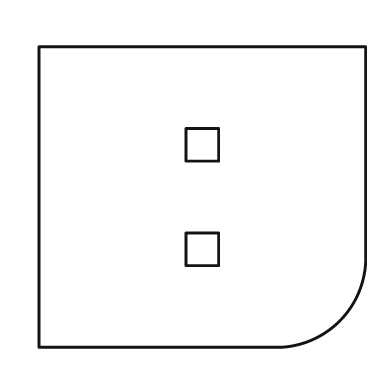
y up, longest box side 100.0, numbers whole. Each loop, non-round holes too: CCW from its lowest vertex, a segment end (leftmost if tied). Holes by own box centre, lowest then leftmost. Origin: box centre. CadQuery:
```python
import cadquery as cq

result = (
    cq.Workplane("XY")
    .moveTo(-50.0, -46.0)
    .lineTo(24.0, -46.0)
    .threePointArc((42.0, -38.0), (50.0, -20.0))
    .lineTo(50.0, 46.0)
    .lineTo(-50.0, 46.0)
    .close()
    .moveTo(-5.0, -21.0)
    .lineTo(5.0, -21.0)
    .lineTo(5.0, -11.0)
    .lineTo(-5.0, -11.0)
    .close()
    .moveTo(-5.0, 11.0)
    .lineTo(5.0, 11.0)
    .lineTo(5.0, 21.0)
    .lineTo(-5.0, 21.0)
    .close()
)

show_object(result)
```